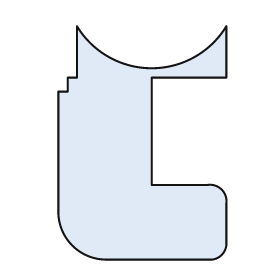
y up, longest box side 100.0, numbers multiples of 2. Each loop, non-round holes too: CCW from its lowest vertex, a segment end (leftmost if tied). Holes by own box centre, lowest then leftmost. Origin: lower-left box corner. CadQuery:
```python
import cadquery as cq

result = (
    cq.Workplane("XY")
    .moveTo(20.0, 0.0)
    .lineTo(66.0, 0.0)
    .threePointArc((70.0, 2.0), (72.0, 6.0))
    .lineTo(72.0, 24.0)
    .threePointArc((70.0, 30.0), (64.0, 32.0))
    .lineTo(40.0, 32.0)
    .lineTo(40.0, 78.0)
    .lineTo(72.0, 78.0)
    .lineTo(72.0, 100.0)
    .threePointArc((40.0, 82.0), (8.0, 100.0))
    .lineTo(8.0, 78.0)
    .lineTo(4.0, 78.0)
    .lineTo(4.0, 72.0)
    .lineTo(0.0, 72.0)
    .lineTo(0.0, 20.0)
    .threePointArc((6.0, 6.0), (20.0, 0.0))
    .close()
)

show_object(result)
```